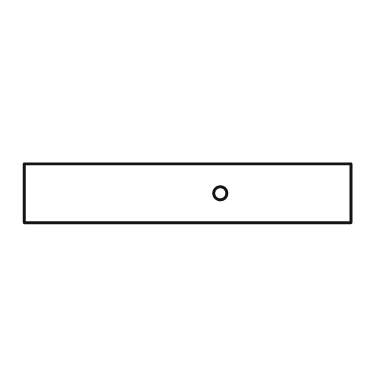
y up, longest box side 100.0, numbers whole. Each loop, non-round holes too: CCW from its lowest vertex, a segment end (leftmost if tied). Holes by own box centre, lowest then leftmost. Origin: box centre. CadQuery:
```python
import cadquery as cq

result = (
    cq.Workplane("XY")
    .moveTo(-50.0, -9.0)
    .lineTo(50.0, -9.0)
    .lineTo(50.0, 9.0)
    .lineTo(-50.0, 9.0)
    .close()
    .moveTo(10.0, 0.0)
    .circle(2.0)
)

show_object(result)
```